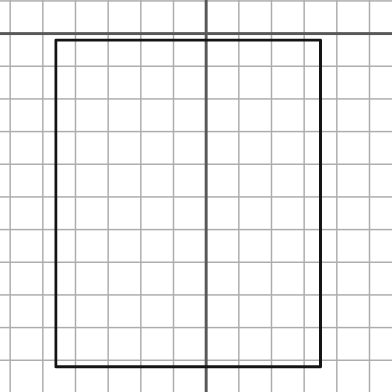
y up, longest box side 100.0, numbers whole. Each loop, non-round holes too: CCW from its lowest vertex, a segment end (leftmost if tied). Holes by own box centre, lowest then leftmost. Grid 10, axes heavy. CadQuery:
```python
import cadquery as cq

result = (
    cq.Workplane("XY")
    .moveTo(-46.0, -102.0)
    .lineTo(35.0, -102.0)
    .lineTo(35.0, -2.0)
    .lineTo(-46.0, -2.0)
    .close()
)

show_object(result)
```